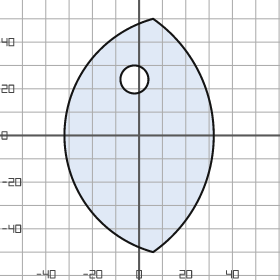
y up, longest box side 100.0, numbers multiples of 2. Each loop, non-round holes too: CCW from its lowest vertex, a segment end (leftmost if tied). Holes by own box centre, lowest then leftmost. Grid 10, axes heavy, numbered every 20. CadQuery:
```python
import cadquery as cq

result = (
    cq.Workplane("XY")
    .moveTo(6.0, -50.0)
    .threePointArc((32.0, 0.0), (6.0, 50.0))
    .threePointArc((-32.0, 0.0), (6.0, -50.0))
    .close()
    .moveTo(-2.0, 24.0)
    .circle(6.0)
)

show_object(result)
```